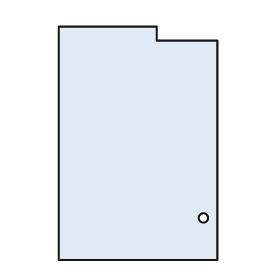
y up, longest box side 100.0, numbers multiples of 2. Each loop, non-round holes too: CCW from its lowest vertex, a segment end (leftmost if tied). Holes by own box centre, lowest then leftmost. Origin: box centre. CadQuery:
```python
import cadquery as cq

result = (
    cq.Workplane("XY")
    .moveTo(-34.0, -50.0)
    .lineTo(34.0, -50.0)
    .lineTo(34.0, 44.0)
    .lineTo(8.0, 44.0)
    .lineTo(8.0, 50.0)
    .lineTo(-34.0, 50.0)
    .close()
    .moveTo(28.0, -32.0)
    .circle(2.0)
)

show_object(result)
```